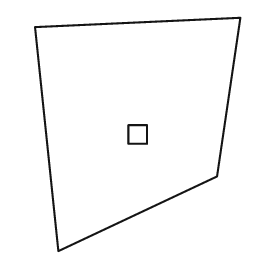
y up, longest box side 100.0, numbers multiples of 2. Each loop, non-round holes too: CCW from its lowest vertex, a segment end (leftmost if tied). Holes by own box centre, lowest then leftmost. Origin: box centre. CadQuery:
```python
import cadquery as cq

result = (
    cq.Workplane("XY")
    .moveTo(-34.0, -50.0)
    .lineTo(34.0, -18.0)
    .lineTo(44.0, 50.0)
    .lineTo(-44.0, 46.0)
    .close()
    .moveTo(-4.0, -4.0)
    .lineTo(4.0, -4.0)
    .lineTo(4.0, 4.0)
    .lineTo(-4.0, 4.0)
    .close()
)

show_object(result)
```